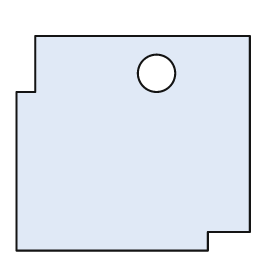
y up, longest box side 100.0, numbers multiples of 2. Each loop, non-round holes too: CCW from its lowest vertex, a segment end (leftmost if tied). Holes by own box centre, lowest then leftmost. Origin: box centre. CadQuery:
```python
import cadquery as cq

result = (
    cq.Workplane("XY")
    .moveTo(-50.0, -46.0)
    .lineTo(32.0, -46.0)
    .lineTo(32.0, -38.0)
    .lineTo(50.0, -38.0)
    .lineTo(50.0, 46.0)
    .lineTo(-42.0, 46.0)
    .lineTo(-42.0, 22.0)
    .lineTo(-50.0, 22.0)
    .close()
    .moveTo(10.0, 30.0)
    .circle(8.0)
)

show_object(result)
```